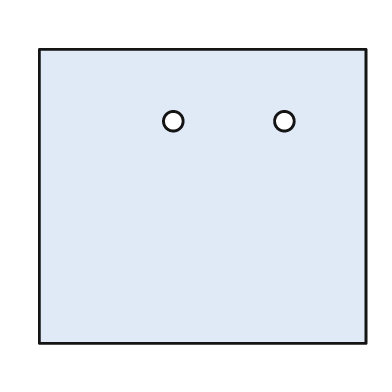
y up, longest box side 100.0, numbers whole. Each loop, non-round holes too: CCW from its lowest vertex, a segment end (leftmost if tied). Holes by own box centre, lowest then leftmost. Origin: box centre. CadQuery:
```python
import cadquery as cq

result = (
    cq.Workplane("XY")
    .moveTo(-50.0, -45.0)
    .lineTo(50.0, -45.0)
    .lineTo(50.0, 45.0)
    .lineTo(-50.0, 45.0)
    .close()
    .moveTo(-9.0, 23.0)
    .circle(3.0)
    .moveTo(25.0, 23.0)
    .circle(3.0)
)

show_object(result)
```